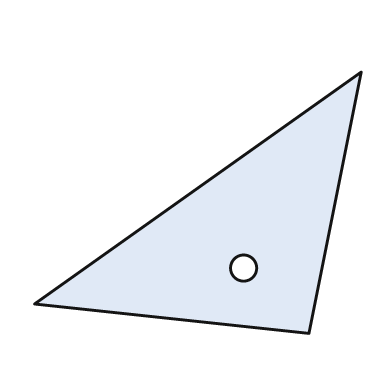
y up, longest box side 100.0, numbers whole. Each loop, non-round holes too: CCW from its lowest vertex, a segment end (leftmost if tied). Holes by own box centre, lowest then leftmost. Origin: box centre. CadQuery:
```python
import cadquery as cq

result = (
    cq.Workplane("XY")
    .moveTo(34.0, -40.0)
    .lineTo(50.0, 40.0)
    .lineTo(-50.0, -31.0)
    .close()
    .moveTo(14.0, -20.0)
    .circle(4.0)
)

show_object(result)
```